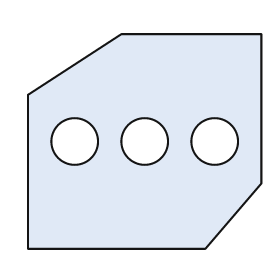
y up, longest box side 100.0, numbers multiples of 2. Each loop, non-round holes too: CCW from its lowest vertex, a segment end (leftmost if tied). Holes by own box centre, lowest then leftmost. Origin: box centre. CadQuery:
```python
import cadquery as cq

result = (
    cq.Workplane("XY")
    .moveTo(-50.0, -46.0)
    .lineTo(26.0, -46.0)
    .lineTo(50.0, -18.0)
    .lineTo(50.0, 46.0)
    .lineTo(-10.0, 46.0)
    .lineTo(-50.0, 20.0)
    .close()
    .moveTo(-30.0, 0.0)
    .circle(10.0)
    .moveTo(0.0, 0.0)
    .circle(10.0)
    .moveTo(30.0, 0.0)
    .circle(10.0)
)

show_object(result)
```